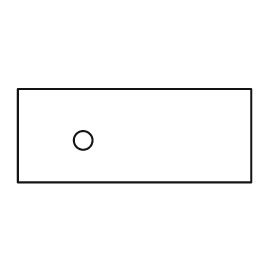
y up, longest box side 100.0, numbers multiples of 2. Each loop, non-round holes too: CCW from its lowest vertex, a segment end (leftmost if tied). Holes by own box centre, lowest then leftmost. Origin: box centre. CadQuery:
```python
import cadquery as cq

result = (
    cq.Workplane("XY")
    .moveTo(-50.0, -20.0)
    .lineTo(50.0, -20.0)
    .lineTo(50.0, 20.0)
    .lineTo(-50.0, 20.0)
    .close()
    .moveTo(-22.0, -2.0)
    .circle(4.0)
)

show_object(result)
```